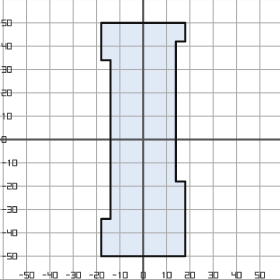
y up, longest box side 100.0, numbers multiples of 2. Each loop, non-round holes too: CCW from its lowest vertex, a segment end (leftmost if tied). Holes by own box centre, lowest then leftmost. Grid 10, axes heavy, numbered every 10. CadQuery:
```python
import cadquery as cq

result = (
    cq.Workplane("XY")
    .moveTo(-18.0, -50.0)
    .lineTo(18.0, -50.0)
    .lineTo(18.0, -18.0)
    .lineTo(14.0, -18.0)
    .lineTo(14.0, 42.0)
    .lineTo(18.0, 42.0)
    .lineTo(18.0, 50.0)
    .lineTo(-18.0, 50.0)
    .lineTo(-18.0, 34.0)
    .lineTo(-14.0, 34.0)
    .lineTo(-14.0, -34.0)
    .lineTo(-18.0, -34.0)
    .close()
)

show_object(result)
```